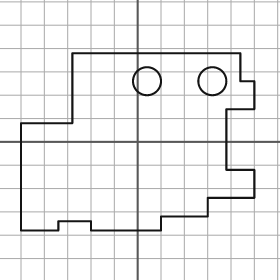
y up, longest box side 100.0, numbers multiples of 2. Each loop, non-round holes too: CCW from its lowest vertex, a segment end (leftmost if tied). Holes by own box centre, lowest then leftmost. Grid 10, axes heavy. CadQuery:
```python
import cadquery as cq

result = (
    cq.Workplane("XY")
    .moveTo(-50.0, -38.0)
    .lineTo(-34.0, -38.0)
    .lineTo(-34.0, -34.0)
    .lineTo(-20.0, -34.0)
    .lineTo(-20.0, -38.0)
    .lineTo(10.0, -38.0)
    .lineTo(10.0, -32.0)
    .lineTo(30.0, -32.0)
    .lineTo(30.0, -24.0)
    .lineTo(50.0, -24.0)
    .lineTo(50.0, -12.0)
    .lineTo(38.0, -12.0)
    .lineTo(38.0, 14.0)
    .lineTo(50.0, 14.0)
    .lineTo(50.0, 26.0)
    .lineTo(44.0, 26.0)
    .lineTo(44.0, 38.0)
    .lineTo(-28.0, 38.0)
    .lineTo(-28.0, 8.0)
    .lineTo(-50.0, 8.0)
    .close()
    .moveTo(4.0, 26.0)
    .circle(6.0)
    .moveTo(32.0, 26.0)
    .circle(6.0)
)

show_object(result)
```